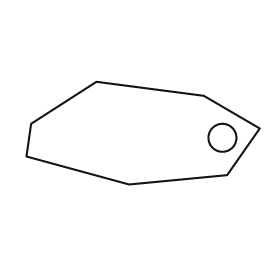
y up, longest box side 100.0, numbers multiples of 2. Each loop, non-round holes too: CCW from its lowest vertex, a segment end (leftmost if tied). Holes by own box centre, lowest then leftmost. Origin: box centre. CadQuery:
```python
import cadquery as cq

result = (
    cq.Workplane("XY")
    .moveTo(-6.0, -22.0)
    .lineTo(36.0, -18.0)
    .lineTo(50.0, 2.0)
    .lineTo(26.0, 16.0)
    .lineTo(-20.0, 22.0)
    .lineTo(-48.0, 4.0)
    .lineTo(-50.0, -10.0)
    .close()
    .moveTo(34.0, -2.0)
    .circle(6.0)
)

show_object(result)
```